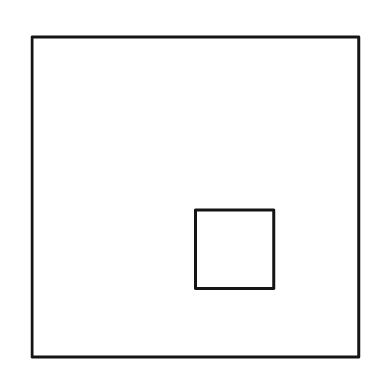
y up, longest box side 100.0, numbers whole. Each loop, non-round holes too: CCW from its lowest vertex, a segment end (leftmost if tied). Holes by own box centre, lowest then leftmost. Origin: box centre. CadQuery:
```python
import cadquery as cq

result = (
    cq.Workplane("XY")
    .moveTo(-50.0, -49.0)
    .lineTo(50.0, -49.0)
    .lineTo(50.0, 49.0)
    .lineTo(-50.0, 49.0)
    .close()
    .moveTo(0.0, -28.0)
    .lineTo(24.0, -28.0)
    .lineTo(24.0, -4.0)
    .lineTo(0.0, -4.0)
    .close()
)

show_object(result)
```